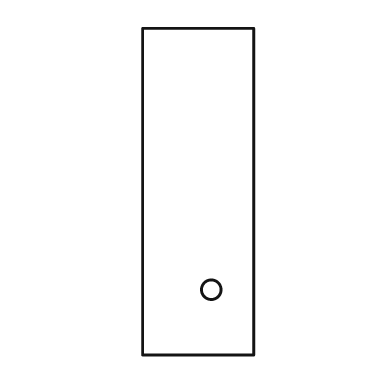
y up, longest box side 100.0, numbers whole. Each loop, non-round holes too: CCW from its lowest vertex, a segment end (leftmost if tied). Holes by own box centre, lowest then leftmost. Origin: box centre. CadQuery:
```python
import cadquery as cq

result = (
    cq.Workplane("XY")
    .moveTo(-17.0, -50.0)
    .lineTo(17.0, -50.0)
    .lineTo(17.0, 50.0)
    .lineTo(-17.0, 50.0)
    .close()
    .moveTo(4.0, -30.0)
    .circle(3.0)
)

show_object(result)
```